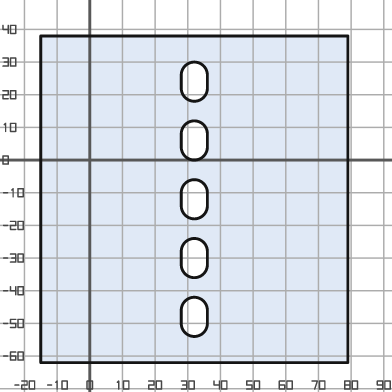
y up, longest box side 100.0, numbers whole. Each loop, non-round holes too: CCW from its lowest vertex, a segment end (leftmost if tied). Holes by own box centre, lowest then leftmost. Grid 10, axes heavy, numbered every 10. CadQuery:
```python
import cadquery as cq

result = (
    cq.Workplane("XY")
    .moveTo(-15.0, -62.0)
    .lineTo(79.0, -62.0)
    .lineTo(79.0, 38.0)
    .lineTo(-15.0, 38.0)
    .close()
    .moveTo(28.0, -50.0)
    .threePointArc((32.0, -54.0), (36.0, -50.0))
    .lineTo(36.0, -46.0)
    .threePointArc((32.0, -42.0), (28.0, -46.0))
    .close()
    .moveTo(28.0, -32.0)
    .threePointArc((32.0, -36.0), (36.0, -32.0))
    .lineTo(36.0, -28.0)
    .threePointArc((32.0, -24.0), (28.0, -28.0))
    .close()
    .moveTo(28.0, -14.0)
    .threePointArc((32.0, -18.0), (36.0, -14.0))
    .lineTo(36.0, -10.0)
    .threePointArc((32.0, -6.0), (28.0, -10.0))
    .close()
    .moveTo(28.0, 4.0)
    .threePointArc((32.0, 0.0), (36.0, 4.0))
    .lineTo(36.0, 8.0)
    .threePointArc((32.0, 12.0), (28.0, 8.0))
    .close()
    .moveTo(28.0, 22.0)
    .threePointArc((32.0, 18.0), (36.0, 22.0))
    .lineTo(36.0, 26.0)
    .threePointArc((32.0, 30.0), (28.0, 26.0))
    .close()
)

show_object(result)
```